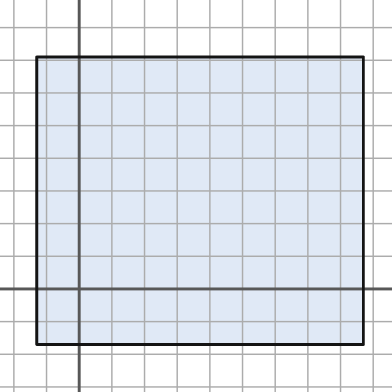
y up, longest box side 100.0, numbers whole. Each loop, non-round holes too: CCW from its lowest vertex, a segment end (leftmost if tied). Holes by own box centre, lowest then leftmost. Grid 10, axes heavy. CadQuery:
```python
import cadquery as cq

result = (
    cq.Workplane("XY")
    .moveTo(-13.0, -17.0)
    .lineTo(87.0, -17.0)
    .lineTo(87.0, 71.0)
    .lineTo(-13.0, 71.0)
    .close()
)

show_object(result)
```